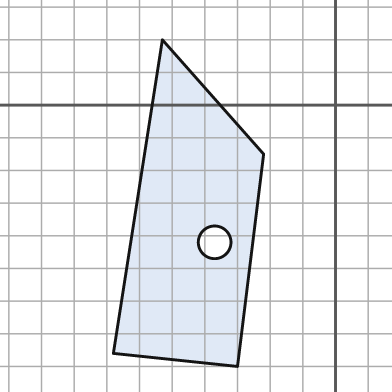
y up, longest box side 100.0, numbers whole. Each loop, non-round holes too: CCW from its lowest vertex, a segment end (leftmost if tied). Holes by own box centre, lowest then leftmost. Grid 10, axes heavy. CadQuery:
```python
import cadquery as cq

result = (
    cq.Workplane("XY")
    .moveTo(-30.0, -80.0)
    .lineTo(-22.0, -15.0)
    .lineTo(-53.0, 20.0)
    .lineTo(-68.0, -76.0)
    .close()
    .moveTo(-37.0, -42.0)
    .circle(5.0)
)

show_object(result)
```